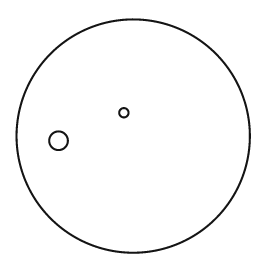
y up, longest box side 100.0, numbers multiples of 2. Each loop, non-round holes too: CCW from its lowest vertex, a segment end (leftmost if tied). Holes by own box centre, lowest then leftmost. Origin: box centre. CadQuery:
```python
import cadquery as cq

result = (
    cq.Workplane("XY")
    .moveTo(0.0, 0.0)
    .circle(50.0)
    .moveTo(-32.0, -2.0)
    .circle(4.0)
    .moveTo(-4.0, 10.0)
    .circle(2.0)
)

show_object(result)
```